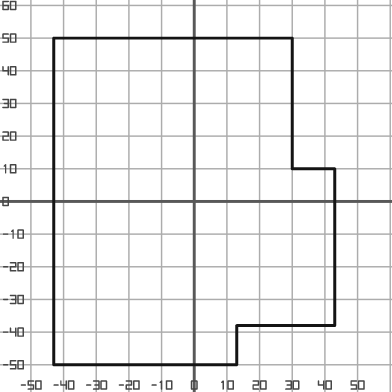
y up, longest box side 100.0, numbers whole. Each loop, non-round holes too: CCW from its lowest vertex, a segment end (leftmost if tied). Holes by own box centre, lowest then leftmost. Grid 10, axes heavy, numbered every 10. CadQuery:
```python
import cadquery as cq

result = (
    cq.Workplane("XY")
    .moveTo(-43.0, -50.0)
    .lineTo(13.0, -50.0)
    .lineTo(13.0, -38.0)
    .lineTo(43.0, -38.0)
    .lineTo(43.0, 10.0)
    .lineTo(30.0, 10.0)
    .lineTo(30.0, 50.0)
    .lineTo(-43.0, 50.0)
    .close()
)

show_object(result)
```